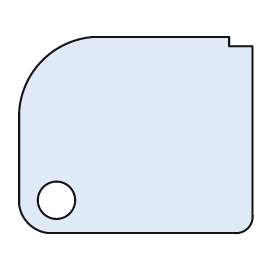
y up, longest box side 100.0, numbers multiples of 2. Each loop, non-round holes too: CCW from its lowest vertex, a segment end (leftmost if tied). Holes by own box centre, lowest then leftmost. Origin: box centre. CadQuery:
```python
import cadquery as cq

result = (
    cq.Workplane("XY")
    .moveTo(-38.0, -42.0)
    .lineTo(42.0, -42.0)
    .threePointArc((48.0, -40.0), (50.0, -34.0))
    .lineTo(50.0, 38.0)
    .lineTo(40.0, 38.0)
    .lineTo(40.0, 42.0)
    .lineTo(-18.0, 42.0)
    .threePointArc((-40.0, 32.0), (-50.0, 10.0))
    .lineTo(-50.0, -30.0)
    .threePointArc((-46.0, -38.0), (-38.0, -42.0))
    .close()
    .moveTo(-34.0, -28.0)
    .circle(8.0)
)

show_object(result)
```